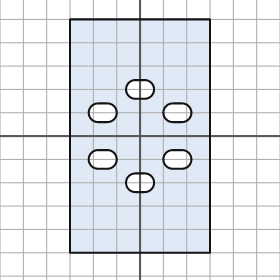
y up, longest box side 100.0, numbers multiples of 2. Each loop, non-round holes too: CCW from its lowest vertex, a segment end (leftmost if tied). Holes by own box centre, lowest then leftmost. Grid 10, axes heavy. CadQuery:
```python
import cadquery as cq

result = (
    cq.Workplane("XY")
    .moveTo(-30.0, -50.0)
    .lineTo(30.0, -50.0)
    .lineTo(30.0, 50.0)
    .lineTo(-30.0, 50.0)
    .close()
    .moveTo(-2.0, -24.0)
    .lineTo(2.0, -24.0)
    .threePointArc((6.0, -20.0), (2.0, -16.0))
    .lineTo(-2.0, -16.0)
    .threePointArc((-6.0, -20.0), (-2.0, -24.0))
    .close()
    .moveTo(-18.0, -14.0)
    .lineTo(-14.0, -14.0)
    .threePointArc((-10.0, -10.0), (-14.0, -6.0))
    .lineTo(-18.0, -6.0)
    .threePointArc((-22.0, -10.0), (-18.0, -14.0))
    .close()
    .moveTo(14.0, -14.0)
    .lineTo(18.0, -14.0)
    .threePointArc((22.0, -10.0), (18.0, -6.0))
    .lineTo(14.0, -6.0)
    .threePointArc((10.0, -10.0), (14.0, -14.0))
    .close()
    .moveTo(-18.0, 6.0)
    .lineTo(-14.0, 6.0)
    .threePointArc((-10.0, 10.0), (-14.0, 14.0))
    .lineTo(-18.0, 14.0)
    .threePointArc((-22.0, 10.0), (-18.0, 6.0))
    .close()
    .moveTo(14.0, 6.0)
    .lineTo(18.0, 6.0)
    .threePointArc((22.0, 10.0), (18.0, 14.0))
    .lineTo(14.0, 14.0)
    .threePointArc((10.0, 10.0), (14.0, 6.0))
    .close()
    .moveTo(-2.0, 16.0)
    .lineTo(2.0, 16.0)
    .threePointArc((6.0, 20.0), (2.0, 24.0))
    .lineTo(-2.0, 24.0)
    .threePointArc((-6.0, 20.0), (-2.0, 16.0))
    .close()
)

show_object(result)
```